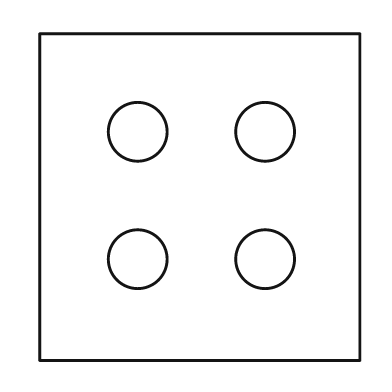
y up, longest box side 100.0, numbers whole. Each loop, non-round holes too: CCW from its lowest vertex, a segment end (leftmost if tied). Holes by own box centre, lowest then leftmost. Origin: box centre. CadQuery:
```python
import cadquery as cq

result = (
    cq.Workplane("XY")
    .moveTo(-49.0, -50.0)
    .lineTo(49.0, -50.0)
    .lineTo(49.0, 50.0)
    .lineTo(-49.0, 50.0)
    .close()
    .moveTo(-19.0, -19.0)
    .circle(9.0)
    .moveTo(20.0, -19.0)
    .circle(9.0)
    .moveTo(-19.0, 20.0)
    .circle(9.0)
    .moveTo(20.0, 20.0)
    .circle(9.0)
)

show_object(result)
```